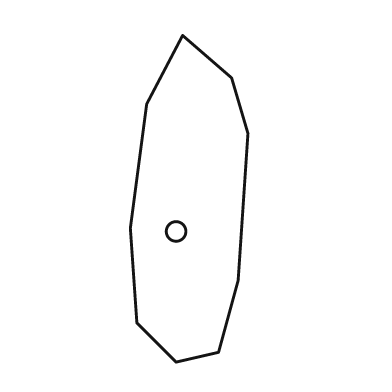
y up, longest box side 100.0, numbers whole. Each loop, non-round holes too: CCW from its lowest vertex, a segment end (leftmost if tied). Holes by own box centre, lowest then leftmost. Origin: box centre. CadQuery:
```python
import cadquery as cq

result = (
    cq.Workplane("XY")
    .moveTo(-4.0, -50.0)
    .lineTo(9.0, -47.0)
    .lineTo(15.0, -25.0)
    .lineTo(18.0, 20.0)
    .lineTo(13.0, 37.0)
    .lineTo(-2.0, 50.0)
    .lineTo(-13.0, 29.0)
    .lineTo(-18.0, -9.0)
    .lineTo(-16.0, -38.0)
    .close()
    .moveTo(-4.0, -10.0)
    .circle(3.0)
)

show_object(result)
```